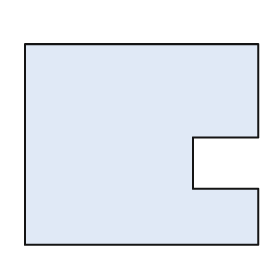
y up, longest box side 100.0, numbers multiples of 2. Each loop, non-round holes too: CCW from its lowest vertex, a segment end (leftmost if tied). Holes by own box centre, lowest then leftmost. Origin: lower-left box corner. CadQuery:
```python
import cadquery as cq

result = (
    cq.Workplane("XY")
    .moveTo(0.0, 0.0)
    .lineTo(100.0, 0.0)
    .lineTo(100.0, 24.0)
    .lineTo(72.0, 24.0)
    .lineTo(72.0, 46.0)
    .lineTo(100.0, 46.0)
    .lineTo(100.0, 86.0)
    .lineTo(0.0, 86.0)
    .close()
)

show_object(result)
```